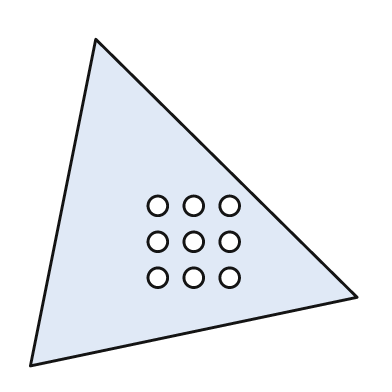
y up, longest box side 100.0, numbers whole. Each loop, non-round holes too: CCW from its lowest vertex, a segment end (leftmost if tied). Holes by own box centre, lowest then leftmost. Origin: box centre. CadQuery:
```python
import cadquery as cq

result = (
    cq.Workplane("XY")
    .moveTo(-50.0, -50.0)
    .lineTo(50.0, -29.0)
    .lineTo(-30.0, 50.0)
    .close()
    .moveTo(-11.0, -23.0)
    .circle(3.0)
    .moveTo(0.0, -23.0)
    .circle(3.0)
    .moveTo(11.0, -23.0)
    .circle(3.0)
    .moveTo(-11.0, -12.0)
    .circle(3.0)
    .moveTo(0.0, -12.0)
    .circle(3.0)
    .moveTo(11.0, -12.0)
    .circle(3.0)
    .moveTo(-11.0, -1.0)
    .circle(3.0)
    .moveTo(0.0, -1.0)
    .circle(3.0)
    .moveTo(11.0, -1.0)
    .circle(3.0)
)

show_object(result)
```